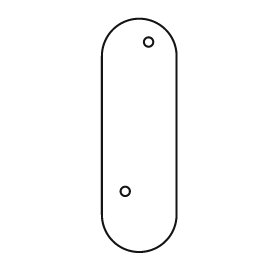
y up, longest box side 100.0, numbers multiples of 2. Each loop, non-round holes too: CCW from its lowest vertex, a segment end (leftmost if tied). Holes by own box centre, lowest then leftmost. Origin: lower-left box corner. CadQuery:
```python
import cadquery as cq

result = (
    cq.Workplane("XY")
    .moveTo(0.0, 16.0)
    .threePointArc((16.0, 0.0), (32.0, 16.0))
    .lineTo(32.0, 84.0)
    .threePointArc((16.0, 100.0), (0.0, 84.0))
    .close()
    .moveTo(10.0, 26.0)
    .circle(2.0)
    .moveTo(20.0, 90.0)
    .circle(2.0)
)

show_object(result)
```